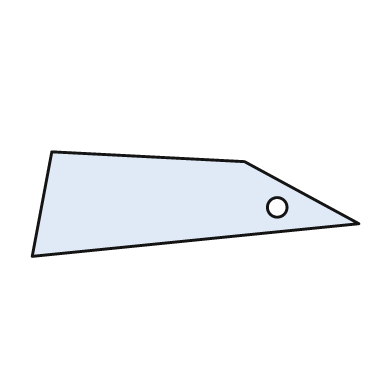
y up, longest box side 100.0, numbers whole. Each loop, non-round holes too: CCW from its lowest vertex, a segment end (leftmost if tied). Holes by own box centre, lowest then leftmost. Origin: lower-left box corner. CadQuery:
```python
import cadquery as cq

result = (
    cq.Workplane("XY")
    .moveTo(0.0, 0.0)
    .lineTo(100.0, 10.0)
    .lineTo(65.0, 29.0)
    .lineTo(6.0, 32.0)
    .close()
    .moveTo(75.0, 15.0)
    .circle(3.0)
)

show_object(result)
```